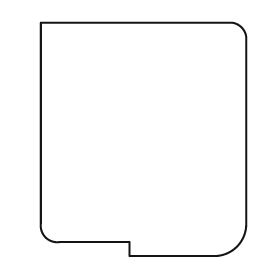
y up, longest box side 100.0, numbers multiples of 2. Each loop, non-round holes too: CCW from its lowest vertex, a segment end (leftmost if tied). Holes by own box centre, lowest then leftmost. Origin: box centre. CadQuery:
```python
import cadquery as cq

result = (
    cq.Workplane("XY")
    .moveTo(-6.0, -50.0)
    .lineTo(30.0, -50.0)
    .threePointArc((40.0, -46.0), (44.0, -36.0))
    .lineTo(44.0, 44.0)
    .threePointArc((42.0, 48.0), (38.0, 50.0))
    .lineTo(-44.0, 50.0)
    .lineTo(-44.0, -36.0)
    .threePointArc((-42.0, -42.0), (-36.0, -44.0))
    .lineTo(-6.0, -44.0)
    .close()
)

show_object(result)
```